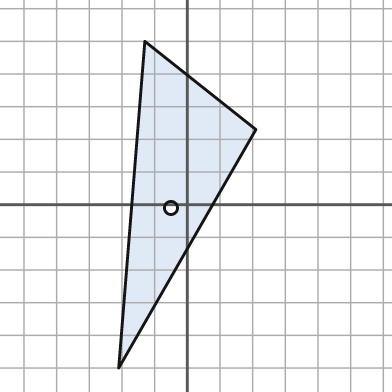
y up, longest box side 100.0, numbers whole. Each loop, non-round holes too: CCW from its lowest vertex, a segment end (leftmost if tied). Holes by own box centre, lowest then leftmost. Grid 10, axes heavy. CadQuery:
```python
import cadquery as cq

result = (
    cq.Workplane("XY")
    .moveTo(-21.0, -50.0)
    .lineTo(21.0, 23.0)
    .lineTo(-13.0, 50.0)
    .close()
    .moveTo(-5.0, -1.0)
    .circle(2.0)
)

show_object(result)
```